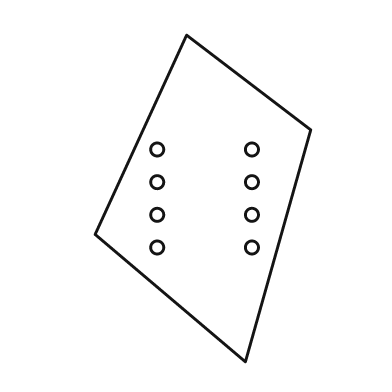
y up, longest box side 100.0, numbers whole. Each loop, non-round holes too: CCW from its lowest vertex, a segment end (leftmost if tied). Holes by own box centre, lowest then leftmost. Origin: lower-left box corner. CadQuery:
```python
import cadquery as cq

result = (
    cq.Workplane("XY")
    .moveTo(46.0, 0.0)
    .lineTo(66.0, 71.0)
    .lineTo(28.0, 100.0)
    .lineTo(0.0, 39.0)
    .close()
    .moveTo(19.0, 35.0)
    .circle(2.0)
    .moveTo(48.0, 35.0)
    .circle(2.0)
    .moveTo(19.0, 45.0)
    .circle(2.0)
    .moveTo(48.0, 45.0)
    .circle(2.0)
    .moveTo(19.0, 55.0)
    .circle(2.0)
    .moveTo(48.0, 55.0)
    .circle(2.0)
    .moveTo(19.0, 65.0)
    .circle(2.0)
    .moveTo(48.0, 65.0)
    .circle(2.0)
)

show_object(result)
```